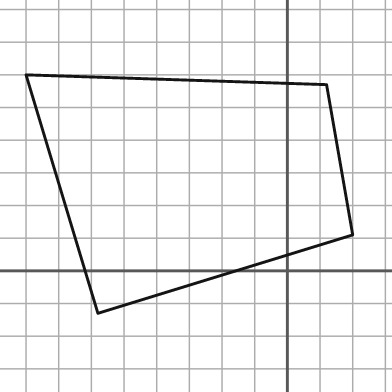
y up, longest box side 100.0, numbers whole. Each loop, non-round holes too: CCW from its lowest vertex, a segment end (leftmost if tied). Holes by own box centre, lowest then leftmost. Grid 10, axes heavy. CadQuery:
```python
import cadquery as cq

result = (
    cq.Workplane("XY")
    .moveTo(-58.0, -13.0)
    .lineTo(20.0, 11.0)
    .lineTo(12.0, 57.0)
    .lineTo(-80.0, 60.0)
    .close()
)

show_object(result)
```